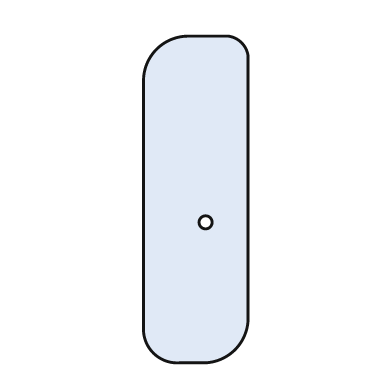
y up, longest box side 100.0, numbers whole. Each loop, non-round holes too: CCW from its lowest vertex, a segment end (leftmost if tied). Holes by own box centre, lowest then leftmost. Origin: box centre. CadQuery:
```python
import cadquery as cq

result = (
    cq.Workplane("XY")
    .moveTo(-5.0, -50.0)
    .lineTo(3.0, -50.0)
    .threePointArc((12.0, -46.0), (16.0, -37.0))
    .lineTo(16.0, 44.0)
    .threePointArc((14.0, 48.0), (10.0, 50.0))
    .lineTo(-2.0, 50.0)
    .threePointArc((-12.0, 46.0), (-16.0, 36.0))
    .lineTo(-16.0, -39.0)
    .threePointArc((-13.0, -47.0), (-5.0, -50.0))
    .close()
    .moveTo(3.0, -7.0)
    .circle(2.0)
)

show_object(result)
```